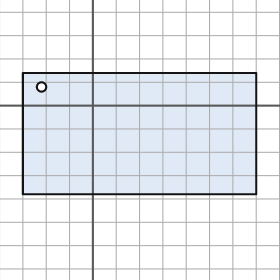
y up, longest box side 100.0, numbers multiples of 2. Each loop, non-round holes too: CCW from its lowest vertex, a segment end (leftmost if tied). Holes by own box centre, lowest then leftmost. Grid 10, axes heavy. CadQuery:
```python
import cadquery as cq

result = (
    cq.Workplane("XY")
    .moveTo(-30.0, -38.0)
    .lineTo(70.0, -38.0)
    .lineTo(70.0, 14.0)
    .lineTo(-30.0, 14.0)
    .close()
    .moveTo(-22.0, 8.0)
    .circle(2.0)
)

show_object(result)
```